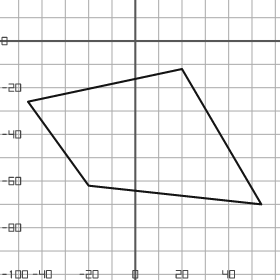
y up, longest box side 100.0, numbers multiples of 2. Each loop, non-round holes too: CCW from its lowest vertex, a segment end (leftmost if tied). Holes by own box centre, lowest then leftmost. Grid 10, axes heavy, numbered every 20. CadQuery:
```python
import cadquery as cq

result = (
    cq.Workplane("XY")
    .moveTo(54.0, -70.0)
    .lineTo(20.0, -12.0)
    .lineTo(-46.0, -26.0)
    .lineTo(-20.0, -62.0)
    .close()
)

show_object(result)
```